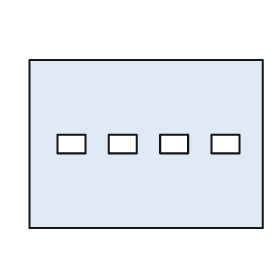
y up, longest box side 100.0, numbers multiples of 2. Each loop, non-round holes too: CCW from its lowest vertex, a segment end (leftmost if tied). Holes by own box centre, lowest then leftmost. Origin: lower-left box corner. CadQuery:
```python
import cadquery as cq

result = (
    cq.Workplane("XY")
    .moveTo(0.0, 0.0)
    .lineTo(100.0, 0.0)
    .lineTo(100.0, 72.0)
    .lineTo(0.0, 72.0)
    .close()
    .moveTo(12.0, 32.0)
    .lineTo(24.0, 32.0)
    .lineTo(24.0, 40.0)
    .lineTo(12.0, 40.0)
    .close()
    .moveTo(34.0, 32.0)
    .lineTo(46.0, 32.0)
    .lineTo(46.0, 40.0)
    .lineTo(34.0, 40.0)
    .close()
    .moveTo(56.0, 32.0)
    .lineTo(68.0, 32.0)
    .lineTo(68.0, 40.0)
    .lineTo(56.0, 40.0)
    .close()
    .moveTo(78.0, 32.0)
    .lineTo(90.0, 32.0)
    .lineTo(90.0, 40.0)
    .lineTo(78.0, 40.0)
    .close()
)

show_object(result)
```